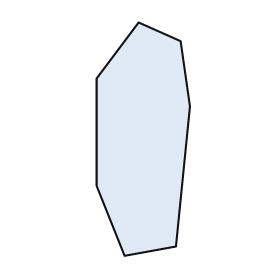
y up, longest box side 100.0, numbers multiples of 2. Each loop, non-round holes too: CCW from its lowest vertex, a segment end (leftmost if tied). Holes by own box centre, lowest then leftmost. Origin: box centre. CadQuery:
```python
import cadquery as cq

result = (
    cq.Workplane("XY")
    .moveTo(-8.0, -50.0)
    .lineTo(14.0, -46.0)
    .lineTo(20.0, 14.0)
    .lineTo(16.0, 42.0)
    .lineTo(-2.0, 50.0)
    .lineTo(-20.0, 26.0)
    .lineTo(-20.0, -20.0)
    .close()
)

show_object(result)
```